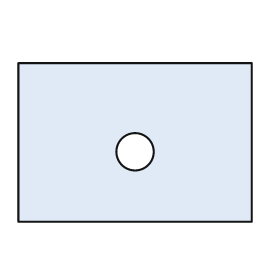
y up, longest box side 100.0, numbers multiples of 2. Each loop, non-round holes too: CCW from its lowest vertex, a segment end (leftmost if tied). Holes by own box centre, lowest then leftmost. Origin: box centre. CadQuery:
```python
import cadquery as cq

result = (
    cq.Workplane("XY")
    .moveTo(-50.0, -34.0)
    .lineTo(50.0, -34.0)
    .lineTo(50.0, 34.0)
    .lineTo(-50.0, 34.0)
    .close()
    .moveTo(0.0, -4.0)
    .circle(8.0)
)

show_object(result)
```